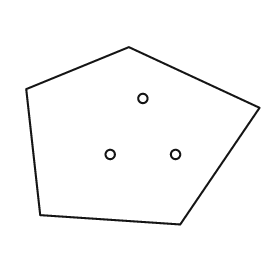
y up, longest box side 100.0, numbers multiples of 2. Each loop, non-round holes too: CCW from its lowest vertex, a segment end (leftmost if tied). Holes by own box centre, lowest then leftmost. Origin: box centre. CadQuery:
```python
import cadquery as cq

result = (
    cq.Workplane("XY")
    .moveTo(16.0, -38.0)
    .lineTo(50.0, 12.0)
    .lineTo(-6.0, 38.0)
    .lineTo(-50.0, 20.0)
    .lineTo(-44.0, -34.0)
    .close()
    .moveTo(-14.0, -8.0)
    .circle(2.0)
    .moveTo(14.0, -8.0)
    .circle(2.0)
    .moveTo(0.0, 16.0)
    .circle(2.0)
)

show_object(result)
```